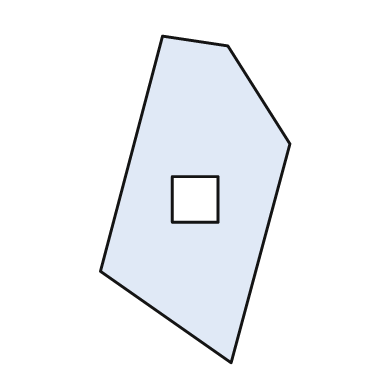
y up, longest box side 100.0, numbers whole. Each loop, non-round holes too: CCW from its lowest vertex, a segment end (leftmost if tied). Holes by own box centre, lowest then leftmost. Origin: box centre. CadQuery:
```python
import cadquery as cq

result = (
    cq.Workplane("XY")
    .moveTo(11.0, -50.0)
    .lineTo(29.0, 17.0)
    .lineTo(10.0, 47.0)
    .lineTo(-10.0, 50.0)
    .lineTo(-29.0, -22.0)
    .close()
    .moveTo(-7.0, -7.0)
    .lineTo(7.0, -7.0)
    .lineTo(7.0, 7.0)
    .lineTo(-7.0, 7.0)
    .close()
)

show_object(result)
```